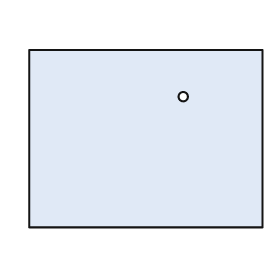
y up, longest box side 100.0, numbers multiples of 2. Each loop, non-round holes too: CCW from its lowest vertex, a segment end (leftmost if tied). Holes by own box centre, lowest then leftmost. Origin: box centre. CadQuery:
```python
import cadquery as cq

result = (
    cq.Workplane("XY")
    .moveTo(-50.0, -38.0)
    .lineTo(50.0, -38.0)
    .lineTo(50.0, 38.0)
    .lineTo(-50.0, 38.0)
    .close()
    .moveTo(16.0, 18.0)
    .circle(2.0)
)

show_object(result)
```